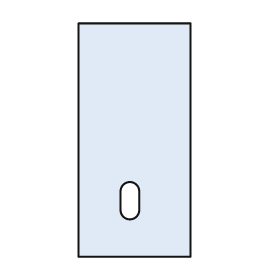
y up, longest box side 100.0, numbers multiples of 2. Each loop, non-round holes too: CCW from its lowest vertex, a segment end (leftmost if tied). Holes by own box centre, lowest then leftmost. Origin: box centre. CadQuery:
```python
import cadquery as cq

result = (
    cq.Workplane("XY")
    .moveTo(-24.0, -50.0)
    .lineTo(24.0, -50.0)
    .lineTo(24.0, 50.0)
    .lineTo(-24.0, 50.0)
    .close()
    .moveTo(-6.0, -30.0)
    .threePointArc((-2.0, -34.0), (2.0, -30.0))
    .lineTo(2.0, -22.0)
    .threePointArc((-2.0, -18.0), (-6.0, -22.0))
    .close()
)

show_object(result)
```